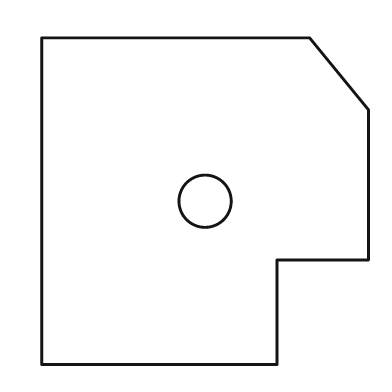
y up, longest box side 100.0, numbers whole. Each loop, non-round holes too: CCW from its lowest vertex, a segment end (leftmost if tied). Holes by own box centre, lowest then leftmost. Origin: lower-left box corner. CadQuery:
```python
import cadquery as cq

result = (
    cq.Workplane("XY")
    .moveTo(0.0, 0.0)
    .lineTo(72.0, 0.0)
    .lineTo(72.0, 32.0)
    .lineTo(100.0, 32.0)
    .lineTo(100.0, 78.0)
    .lineTo(82.0, 100.0)
    .lineTo(0.0, 100.0)
    .close()
    .moveTo(50.0, 50.0)
    .circle(8.0)
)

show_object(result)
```